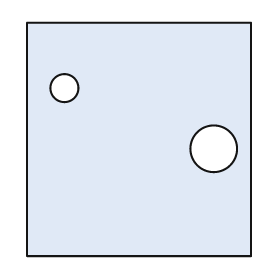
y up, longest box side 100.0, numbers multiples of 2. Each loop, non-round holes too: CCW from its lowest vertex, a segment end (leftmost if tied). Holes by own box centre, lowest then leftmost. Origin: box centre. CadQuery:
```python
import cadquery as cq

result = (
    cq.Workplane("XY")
    .moveTo(-48.0, -50.0)
    .lineTo(48.0, -50.0)
    .lineTo(48.0, 50.0)
    .lineTo(-48.0, 50.0)
    .close()
    .moveTo(32.0, -4.0)
    .circle(10.0)
    .moveTo(-32.0, 22.0)
    .circle(6.0)
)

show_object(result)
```